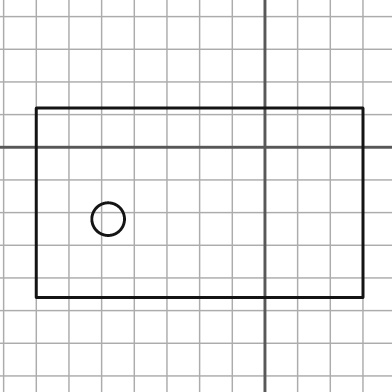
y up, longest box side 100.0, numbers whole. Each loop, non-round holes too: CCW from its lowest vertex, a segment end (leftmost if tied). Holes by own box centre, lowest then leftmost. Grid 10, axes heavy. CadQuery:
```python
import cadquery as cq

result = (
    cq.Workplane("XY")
    .moveTo(-70.0, -46.0)
    .lineTo(30.0, -46.0)
    .lineTo(30.0, 12.0)
    .lineTo(-70.0, 12.0)
    .close()
    .moveTo(-48.0, -22.0)
    .circle(5.0)
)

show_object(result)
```